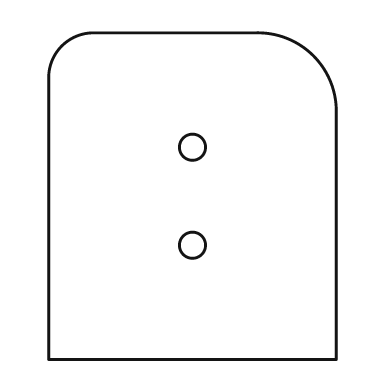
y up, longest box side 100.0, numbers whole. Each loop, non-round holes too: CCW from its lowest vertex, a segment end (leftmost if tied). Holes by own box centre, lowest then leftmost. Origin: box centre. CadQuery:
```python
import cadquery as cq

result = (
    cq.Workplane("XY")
    .moveTo(-44.0, -50.0)
    .lineTo(44.0, -50.0)
    .lineTo(44.0, 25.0)
    .threePointArc((37.0, 43.0), (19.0, 50.0))
    .lineTo(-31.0, 50.0)
    .threePointArc((-40.0, 46.0), (-44.0, 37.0))
    .close()
    .moveTo(0.0, -15.0)
    .circle(4.0)
    .moveTo(0.0, 15.0)
    .circle(4.0)
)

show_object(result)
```